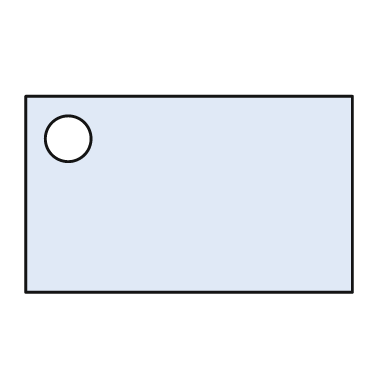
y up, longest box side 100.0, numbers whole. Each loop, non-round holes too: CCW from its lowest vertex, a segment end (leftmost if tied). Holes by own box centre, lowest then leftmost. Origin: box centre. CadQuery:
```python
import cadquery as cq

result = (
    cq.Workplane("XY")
    .moveTo(-50.0, -30.0)
    .lineTo(50.0, -30.0)
    .lineTo(50.0, 30.0)
    .lineTo(-50.0, 30.0)
    .close()
    .moveTo(-37.0, 17.0)
    .circle(7.0)
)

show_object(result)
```